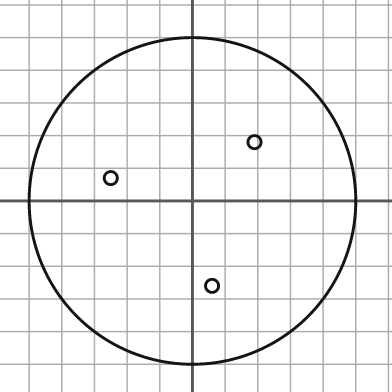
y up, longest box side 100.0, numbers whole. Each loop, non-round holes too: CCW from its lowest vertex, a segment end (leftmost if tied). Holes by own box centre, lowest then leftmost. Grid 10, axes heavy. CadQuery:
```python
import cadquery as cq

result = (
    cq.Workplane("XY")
    .moveTo(0.0, 0.0)
    .circle(50.0)
    .moveTo(6.0, -26.0)
    .circle(2.0)
    .moveTo(-25.0, 7.0)
    .circle(2.0)
    .moveTo(19.0, 18.0)
    .circle(2.0)
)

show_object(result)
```